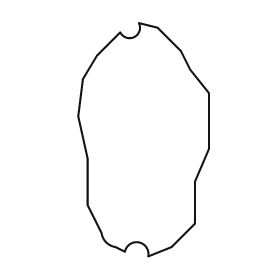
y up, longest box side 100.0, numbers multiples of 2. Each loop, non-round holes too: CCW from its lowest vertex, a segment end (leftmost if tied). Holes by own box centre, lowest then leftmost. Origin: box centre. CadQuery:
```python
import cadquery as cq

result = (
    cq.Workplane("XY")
    .moveTo(2.0, -50.0)
    .lineTo(12.0, -46.0)
    .lineTo(22.0, -36.0)
    .lineTo(22.0, -18.0)
    .lineTo(28.0, -4.0)
    .lineTo(28.0, 20.0)
    .lineTo(20.0, 30.0)
    .lineTo(16.0, 38.0)
    .lineTo(6.0, 48.0)
    .lineTo(-2.0, 50.0)
    .threePointArc((-4.0, 44.0), (-10.0, 46.0))
    .lineTo(-20.0, 36.0)
    .lineTo(-26.0, 26.0)
    .lineTo(-28.0, 10.0)
    .lineTo(-24.0, -8.0)
    .lineTo(-24.0, -28.0)
    .lineTo(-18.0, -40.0)
    .threePointArc((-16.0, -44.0), (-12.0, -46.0))
    .lineTo(-8.0, -48.0)
    .threePointArc((-2.0, -44.0), (2.0, -50.0))
    .close()
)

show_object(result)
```